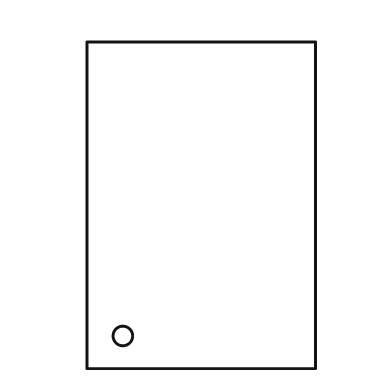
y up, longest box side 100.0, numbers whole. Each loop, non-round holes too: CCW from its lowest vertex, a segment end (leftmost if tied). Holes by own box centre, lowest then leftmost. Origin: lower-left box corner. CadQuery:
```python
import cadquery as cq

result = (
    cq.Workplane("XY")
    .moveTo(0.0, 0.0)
    .lineTo(70.0, 0.0)
    .lineTo(70.0, 100.0)
    .lineTo(0.0, 100.0)
    .close()
    .moveTo(11.0, 10.0)
    .circle(3.0)
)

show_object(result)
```